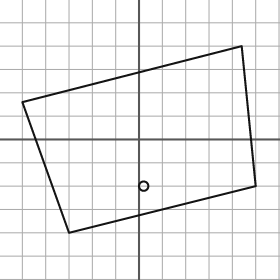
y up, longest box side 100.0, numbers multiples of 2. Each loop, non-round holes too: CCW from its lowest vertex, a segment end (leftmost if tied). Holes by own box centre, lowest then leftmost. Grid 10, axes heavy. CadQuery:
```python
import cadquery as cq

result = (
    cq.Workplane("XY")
    .moveTo(-30.0, -40.0)
    .lineTo(50.0, -20.0)
    .lineTo(44.0, 40.0)
    .lineTo(-50.0, 16.0)
    .close()
    .moveTo(2.0, -20.0)
    .circle(2.0)
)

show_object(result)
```